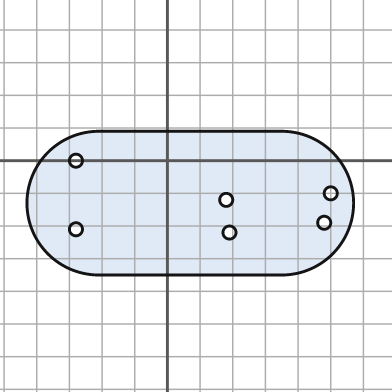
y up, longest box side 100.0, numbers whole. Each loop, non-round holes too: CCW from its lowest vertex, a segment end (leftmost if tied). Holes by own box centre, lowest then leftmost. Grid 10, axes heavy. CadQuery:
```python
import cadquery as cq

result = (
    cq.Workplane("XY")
    .moveTo(-21.0, -35.0)
    .lineTo(35.0, -35.0)
    .threePointArc((57.0, -13.0), (35.0, 9.0))
    .lineTo(-21.0, 9.0)
    .threePointArc((-43.0, -13.0), (-21.0, -35.0))
    .close()
    .moveTo(19.0, -22.0)
    .circle(2.0)
    .moveTo(-28.0, -21.0)
    .circle(2.0)
    .moveTo(48.0, -19.0)
    .circle(2.0)
    .moveTo(18.0, -12.0)
    .circle(2.0)
    .moveTo(50.0, -10.0)
    .circle(2.0)
    .moveTo(-28.0, 0.0)
    .circle(2.0)
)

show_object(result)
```